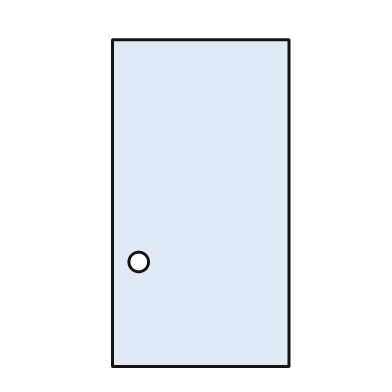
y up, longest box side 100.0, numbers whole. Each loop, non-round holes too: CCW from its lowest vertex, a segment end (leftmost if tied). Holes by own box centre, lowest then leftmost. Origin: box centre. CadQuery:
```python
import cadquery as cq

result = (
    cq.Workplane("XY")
    .moveTo(-27.0, -50.0)
    .lineTo(27.0, -50.0)
    .lineTo(27.0, 50.0)
    .lineTo(-27.0, 50.0)
    .close()
    .moveTo(-19.0, -18.0)
    .circle(3.0)
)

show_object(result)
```